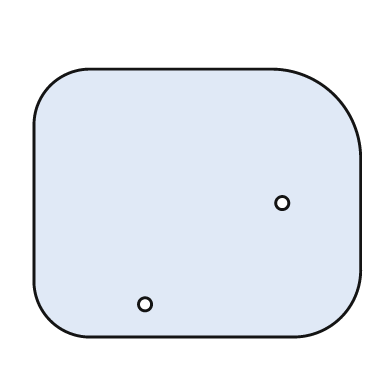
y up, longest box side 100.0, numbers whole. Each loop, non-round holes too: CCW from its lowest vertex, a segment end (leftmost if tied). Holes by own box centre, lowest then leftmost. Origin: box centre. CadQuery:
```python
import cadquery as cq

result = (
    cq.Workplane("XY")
    .moveTo(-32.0, -41.0)
    .lineTo(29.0, -41.0)
    .threePointArc((44.0, -35.0), (50.0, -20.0))
    .lineTo(50.0, 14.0)
    .threePointArc((42.0, 33.0), (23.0, 41.0))
    .lineTo(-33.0, 41.0)
    .threePointArc((-45.0, 36.0), (-50.0, 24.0))
    .lineTo(-50.0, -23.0)
    .threePointArc((-45.0, -36.0), (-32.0, -41.0))
    .close()
    .moveTo(-16.0, -31.0)
    .circle(2.0)
    .moveTo(26.0, 0.0)
    .circle(2.0)
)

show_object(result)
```